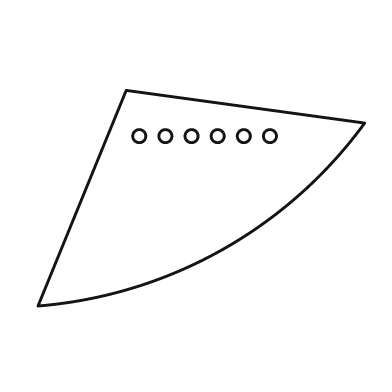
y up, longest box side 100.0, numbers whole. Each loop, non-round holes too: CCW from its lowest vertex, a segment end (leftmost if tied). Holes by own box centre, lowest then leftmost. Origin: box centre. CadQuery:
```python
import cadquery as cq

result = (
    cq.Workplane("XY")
    .moveTo(-50.0, -33.0)
    .threePointArc((6.0, -16.0), (50.0, 23.0))
    .lineTo(-23.0, 33.0)
    .close()
    .moveTo(-19.0, 19.0)
    .circle(2.0)
    .moveTo(-11.0, 19.0)
    .circle(2.0)
    .moveTo(-3.0, 19.0)
    .circle(2.0)
    .moveTo(5.0, 19.0)
    .circle(2.0)
    .moveTo(13.0, 19.0)
    .circle(2.0)
    .moveTo(21.0, 19.0)
    .circle(2.0)
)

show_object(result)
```